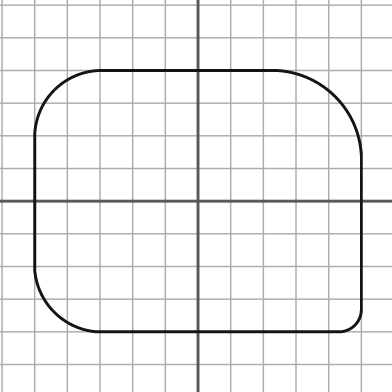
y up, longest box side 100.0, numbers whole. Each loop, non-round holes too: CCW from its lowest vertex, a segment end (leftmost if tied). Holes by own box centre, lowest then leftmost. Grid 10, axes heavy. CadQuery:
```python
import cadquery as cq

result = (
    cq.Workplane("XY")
    .moveTo(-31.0, -40.0)
    .lineTo(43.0, -40.0)
    .threePointArc((48.0, -38.0), (50.0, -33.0))
    .lineTo(50.0, 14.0)
    .threePointArc((42.0, 32.0), (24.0, 40.0))
    .lineTo(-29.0, 40.0)
    .threePointArc((-44.0, 34.0), (-50.0, 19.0))
    .lineTo(-50.0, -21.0)
    .threePointArc((-44.0, -34.0), (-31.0, -40.0))
    .close()
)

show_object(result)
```